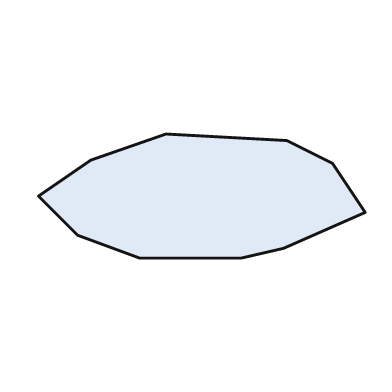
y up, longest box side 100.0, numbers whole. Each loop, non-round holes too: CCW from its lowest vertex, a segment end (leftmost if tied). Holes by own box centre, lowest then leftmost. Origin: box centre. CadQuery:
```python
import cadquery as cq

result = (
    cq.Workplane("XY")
    .moveTo(-19.0, -19.0)
    .lineTo(12.0, -19.0)
    .lineTo(25.0, -16.0)
    .lineTo(50.0, -5.0)
    .lineTo(40.0, 10.0)
    .lineTo(26.0, 17.0)
    .lineTo(-11.0, 19.0)
    .lineTo(-34.0, 11.0)
    .lineTo(-50.0, 0.0)
    .lineTo(-38.0, -12.0)
    .close()
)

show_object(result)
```